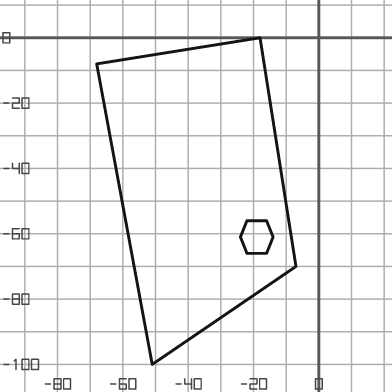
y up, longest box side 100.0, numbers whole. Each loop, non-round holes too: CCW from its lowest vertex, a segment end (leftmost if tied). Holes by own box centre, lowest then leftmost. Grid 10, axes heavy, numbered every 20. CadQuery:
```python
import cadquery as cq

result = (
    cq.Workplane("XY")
    .moveTo(-51.0, -100.0)
    .lineTo(-7.0, -70.0)
    .lineTo(-18.0, 0.0)
    .lineTo(-68.0, -8.0)
    .close()
    .moveTo(-22.0, -66.0)
    .lineTo(-16.0, -66.0)
    .lineTo(-14.0, -61.0)
    .lineTo(-16.0, -56.0)
    .lineTo(-22.0, -56.0)
    .lineTo(-24.0, -61.0)
    .close()
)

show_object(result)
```